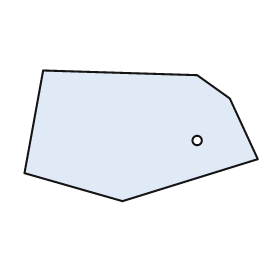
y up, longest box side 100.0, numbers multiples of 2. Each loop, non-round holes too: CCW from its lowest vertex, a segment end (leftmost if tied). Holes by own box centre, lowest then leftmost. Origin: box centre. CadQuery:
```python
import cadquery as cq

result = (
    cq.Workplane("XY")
    .moveTo(-8.0, -28.0)
    .lineTo(50.0, -10.0)
    .lineTo(38.0, 16.0)
    .lineTo(24.0, 26.0)
    .lineTo(-42.0, 28.0)
    .lineTo(-50.0, -16.0)
    .close()
    .moveTo(24.0, -2.0)
    .circle(2.0)
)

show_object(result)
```